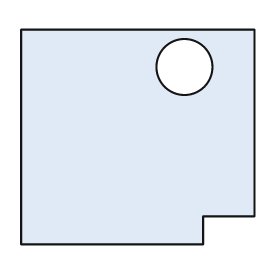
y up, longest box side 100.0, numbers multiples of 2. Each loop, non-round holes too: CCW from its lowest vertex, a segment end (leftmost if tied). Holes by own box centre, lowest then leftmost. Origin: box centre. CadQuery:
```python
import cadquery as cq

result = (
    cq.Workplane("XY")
    .moveTo(-50.0, -46.0)
    .lineTo(28.0, -46.0)
    .lineTo(28.0, -34.0)
    .lineTo(50.0, -34.0)
    .lineTo(50.0, 46.0)
    .lineTo(-50.0, 46.0)
    .close()
    .moveTo(20.0, 30.0)
    .circle(12.0)
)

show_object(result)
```